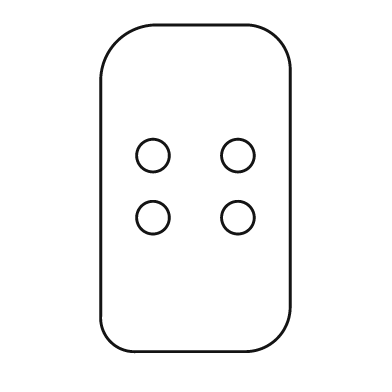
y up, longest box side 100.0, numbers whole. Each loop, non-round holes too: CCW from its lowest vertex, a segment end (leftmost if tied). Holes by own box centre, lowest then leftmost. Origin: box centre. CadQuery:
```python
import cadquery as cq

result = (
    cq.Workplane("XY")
    .moveTo(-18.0, -50.0)
    .lineTo(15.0, -50.0)
    .threePointArc((25.0, -46.0), (29.0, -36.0))
    .lineTo(29.0, 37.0)
    .threePointArc((25.0, 46.0), (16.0, 50.0))
    .lineTo(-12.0, 50.0)
    .threePointArc((-24.0, 45.0), (-29.0, 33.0))
    .lineTo(-29.0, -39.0)
    .threePointArc((-26.0, -47.0), (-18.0, -50.0))
    .close()
    .moveTo(-13.0, -9.0)
    .circle(5.0)
    .moveTo(13.0, -9.0)
    .circle(5.0)
    .moveTo(-13.0, 10.0)
    .circle(5.0)
    .moveTo(13.0, 10.0)
    .circle(5.0)
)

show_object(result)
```